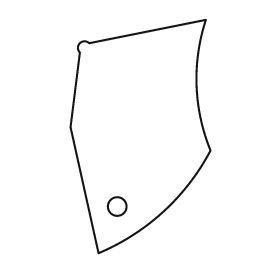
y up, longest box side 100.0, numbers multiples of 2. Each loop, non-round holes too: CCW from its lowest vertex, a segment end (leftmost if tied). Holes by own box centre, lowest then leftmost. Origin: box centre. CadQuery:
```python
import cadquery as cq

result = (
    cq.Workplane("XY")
    .moveTo(-18.0, -50.0)
    .threePointArc((10.0, -32.0), (30.0, -6.0))
    .threePointArc((24.0, 22.0), (28.0, 50.0))
    .lineTo(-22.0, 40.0)
    .threePointArc((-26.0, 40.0), (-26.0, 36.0))
    .lineTo(-30.0, 4.0)
    .close()
    .moveTo(-10.0, -30.0)
    .circle(4.0)
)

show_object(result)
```